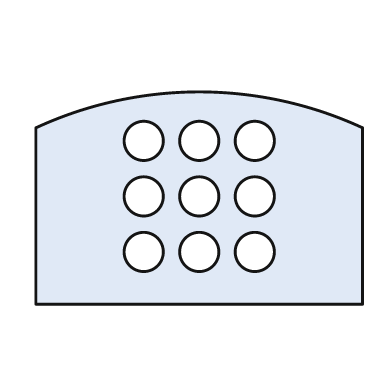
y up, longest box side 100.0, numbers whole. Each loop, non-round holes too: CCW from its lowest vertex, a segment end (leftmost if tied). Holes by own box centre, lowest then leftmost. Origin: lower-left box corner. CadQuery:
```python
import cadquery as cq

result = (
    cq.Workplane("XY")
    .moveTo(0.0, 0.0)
    .lineTo(100.0, 0.0)
    .lineTo(100.0, 54.0)
    .threePointArc((50.0, 65.0), (0.0, 54.0))
    .close()
    .moveTo(33.0, 16.0)
    .circle(6.0)
    .moveTo(50.0, 16.0)
    .circle(6.0)
    .moveTo(67.0, 16.0)
    .circle(6.0)
    .moveTo(33.0, 33.0)
    .circle(6.0)
    .moveTo(50.0, 33.0)
    .circle(6.0)
    .moveTo(67.0, 33.0)
    .circle(6.0)
    .moveTo(33.0, 50.0)
    .circle(6.0)
    .moveTo(50.0, 50.0)
    .circle(6.0)
    .moveTo(67.0, 50.0)
    .circle(6.0)
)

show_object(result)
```